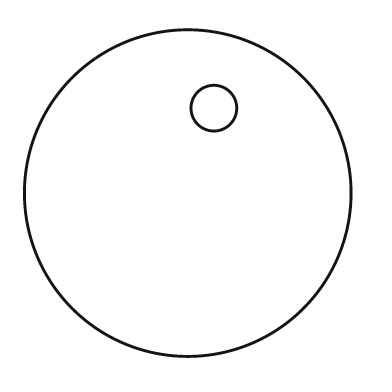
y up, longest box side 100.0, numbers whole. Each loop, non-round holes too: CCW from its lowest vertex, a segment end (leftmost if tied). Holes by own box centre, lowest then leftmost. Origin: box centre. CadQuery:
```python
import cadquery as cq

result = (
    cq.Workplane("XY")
    .moveTo(0.0, 0.0)
    .circle(50.0)
    .moveTo(8.0, 26.0)
    .circle(7.0)
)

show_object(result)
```